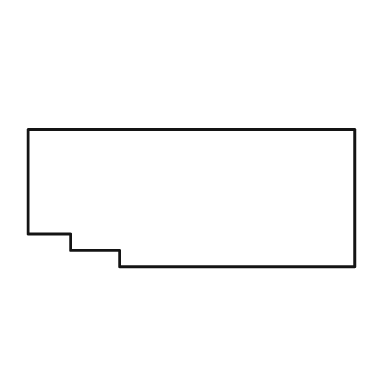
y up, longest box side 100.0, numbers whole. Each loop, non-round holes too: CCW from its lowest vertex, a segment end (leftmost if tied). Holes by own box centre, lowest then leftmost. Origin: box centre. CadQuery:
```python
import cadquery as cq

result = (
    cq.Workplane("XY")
    .moveTo(-22.0, -21.0)
    .lineTo(50.0, -21.0)
    .lineTo(50.0, 21.0)
    .lineTo(-50.0, 21.0)
    .lineTo(-50.0, -11.0)
    .lineTo(-37.0, -11.0)
    .lineTo(-37.0, -16.0)
    .lineTo(-22.0, -16.0)
    .close()
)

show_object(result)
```